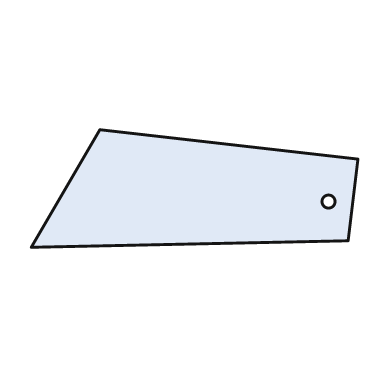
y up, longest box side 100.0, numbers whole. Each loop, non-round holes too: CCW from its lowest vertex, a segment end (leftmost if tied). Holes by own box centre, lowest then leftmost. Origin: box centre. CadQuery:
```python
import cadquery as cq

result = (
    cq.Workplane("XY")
    .moveTo(-50.0, -18.0)
    .lineTo(47.0, -16.0)
    .lineTo(50.0, 9.0)
    .lineTo(-29.0, 18.0)
    .close()
    .moveTo(41.0, -4.0)
    .circle(2.0)
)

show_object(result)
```